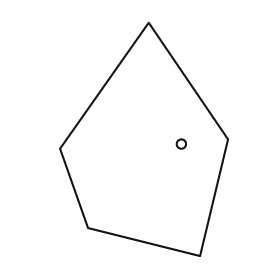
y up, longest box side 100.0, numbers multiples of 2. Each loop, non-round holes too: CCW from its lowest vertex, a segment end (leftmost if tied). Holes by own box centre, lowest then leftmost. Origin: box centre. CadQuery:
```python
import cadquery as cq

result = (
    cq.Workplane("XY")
    .moveTo(24.0, -50.0)
    .lineTo(36.0, 0.0)
    .lineTo(2.0, 50.0)
    .lineTo(-36.0, -4.0)
    .lineTo(-24.0, -38.0)
    .close()
    .moveTo(16.0, -2.0)
    .circle(2.0)
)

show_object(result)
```